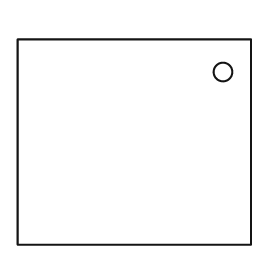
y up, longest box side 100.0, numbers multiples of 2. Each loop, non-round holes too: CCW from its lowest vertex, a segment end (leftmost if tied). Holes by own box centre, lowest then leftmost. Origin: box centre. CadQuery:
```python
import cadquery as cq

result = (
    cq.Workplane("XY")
    .moveTo(-50.0, -44.0)
    .lineTo(50.0, -44.0)
    .lineTo(50.0, 44.0)
    .lineTo(-50.0, 44.0)
    .close()
    .moveTo(38.0, 30.0)
    .circle(4.0)
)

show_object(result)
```